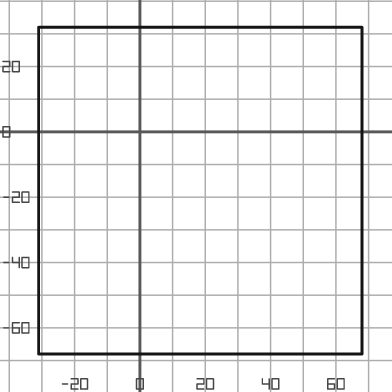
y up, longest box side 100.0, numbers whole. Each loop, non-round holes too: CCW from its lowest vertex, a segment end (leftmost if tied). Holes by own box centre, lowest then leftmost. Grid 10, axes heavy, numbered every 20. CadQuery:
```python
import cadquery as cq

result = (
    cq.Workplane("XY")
    .moveTo(-31.0, -68.0)
    .lineTo(68.0, -68.0)
    .lineTo(68.0, 32.0)
    .lineTo(-31.0, 32.0)
    .close()
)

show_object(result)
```